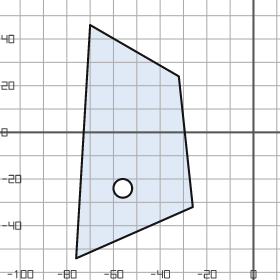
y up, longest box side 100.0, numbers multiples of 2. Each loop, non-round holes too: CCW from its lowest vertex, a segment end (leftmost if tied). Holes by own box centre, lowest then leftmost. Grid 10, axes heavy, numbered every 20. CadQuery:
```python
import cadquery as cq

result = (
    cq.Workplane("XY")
    .moveTo(-76.0, -54.0)
    .lineTo(-26.0, -32.0)
    .lineTo(-32.0, 24.0)
    .lineTo(-70.0, 46.0)
    .close()
    .moveTo(-56.0, -24.0)
    .circle(4.0)
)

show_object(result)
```